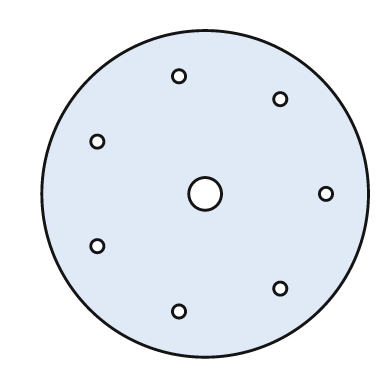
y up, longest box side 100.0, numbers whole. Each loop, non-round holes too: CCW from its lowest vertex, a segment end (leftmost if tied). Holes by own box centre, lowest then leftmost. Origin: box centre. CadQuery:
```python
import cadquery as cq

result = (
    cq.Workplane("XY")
    .moveTo(0.0, 0.0)
    .circle(50.0)
    .moveTo(-8.0, -36.0)
    .circle(2.0)
    .moveTo(23.0, -29.0)
    .circle(2.0)
    .moveTo(-33.0, -16.0)
    .circle(2.0)
    .moveTo(0.0, 0.0)
    .circle(5.0)
    .moveTo(37.0, 0.0)
    .circle(2.0)
    .moveTo(-33.0, 16.0)
    .circle(2.0)
    .moveTo(23.0, 29.0)
    .circle(2.0)
    .moveTo(-8.0, 36.0)
    .circle(2.0)
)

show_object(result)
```